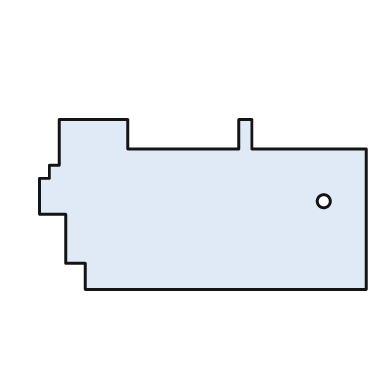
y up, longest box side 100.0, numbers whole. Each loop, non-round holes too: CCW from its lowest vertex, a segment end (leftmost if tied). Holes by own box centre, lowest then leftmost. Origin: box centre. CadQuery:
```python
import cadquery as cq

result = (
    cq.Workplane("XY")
    .moveTo(-36.0, -26.0)
    .lineTo(50.0, -26.0)
    .lineTo(50.0, 17.0)
    .lineTo(15.0, 17.0)
    .lineTo(15.0, 26.0)
    .lineTo(11.0, 26.0)
    .lineTo(11.0, 17.0)
    .lineTo(-23.0, 17.0)
    .lineTo(-23.0, 26.0)
    .lineTo(-44.0, 26.0)
    .lineTo(-44.0, 12.0)
    .lineTo(-47.0, 12.0)
    .lineTo(-47.0, 8.0)
    .lineTo(-50.0, 8.0)
    .lineTo(-50.0, -3.0)
    .lineTo(-42.0, -3.0)
    .lineTo(-42.0, -18.0)
    .lineTo(-36.0, -18.0)
    .close()
    .moveTo(37.0, 1.0)
    .circle(2.0)
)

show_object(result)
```